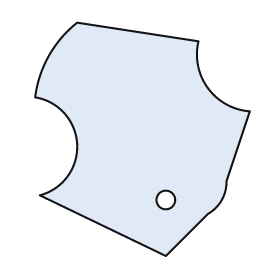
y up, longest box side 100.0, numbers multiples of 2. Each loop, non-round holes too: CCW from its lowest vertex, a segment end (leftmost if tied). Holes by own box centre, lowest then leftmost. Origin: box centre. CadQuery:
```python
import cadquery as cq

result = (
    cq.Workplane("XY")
    .moveTo(10.0, -50.0)
    .lineTo(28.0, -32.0)
    .threePointArc((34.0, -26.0), (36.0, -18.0))
    .lineTo(46.0, 12.0)
    .threePointArc((28.0, 22.0), (24.0, 42.0))
    .lineTo(-28.0, 50.0)
    .threePointArc((-40.0, 36.0), (-46.0, 18.0))
    .threePointArc((-28.0, -2.0), (-44.0, -24.0))
    .close()
    .moveTo(10.0, -26.0)
    .circle(4.0)
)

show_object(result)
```